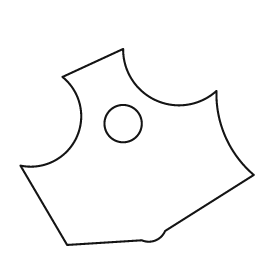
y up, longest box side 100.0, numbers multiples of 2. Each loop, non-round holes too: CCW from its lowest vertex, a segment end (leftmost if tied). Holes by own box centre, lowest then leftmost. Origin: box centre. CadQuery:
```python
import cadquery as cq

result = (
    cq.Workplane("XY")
    .moveTo(-30.0, -42.0)
    .lineTo(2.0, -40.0)
    .threePointArc((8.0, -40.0), (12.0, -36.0))
    .lineTo(50.0, -12.0)
    .threePointArc((38.0, 4.0), (34.0, 24.0))
    .threePointArc((8.0, 20.0), (-6.0, 42.0))
    .lineTo(-32.0, 30.0)
    .threePointArc((-26.0, 4.0), (-50.0, -8.0))
    .close()
    .moveTo(-6.0, 10.0)
    .circle(8.0)
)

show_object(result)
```